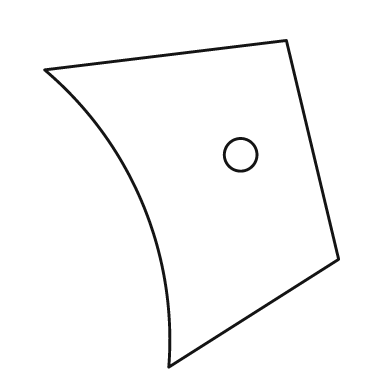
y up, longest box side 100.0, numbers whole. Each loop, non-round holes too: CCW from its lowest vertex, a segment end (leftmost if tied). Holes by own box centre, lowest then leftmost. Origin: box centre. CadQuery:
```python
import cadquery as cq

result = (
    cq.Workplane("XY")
    .moveTo(-7.0, -50.0)
    .lineTo(45.0, -17.0)
    .lineTo(29.0, 50.0)
    .lineTo(-45.0, 41.0)
    .threePointArc((-15.0, 0.0), (-7.0, -50.0))
    .close()
    .moveTo(15.0, 15.0)
    .circle(5.0)
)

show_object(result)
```